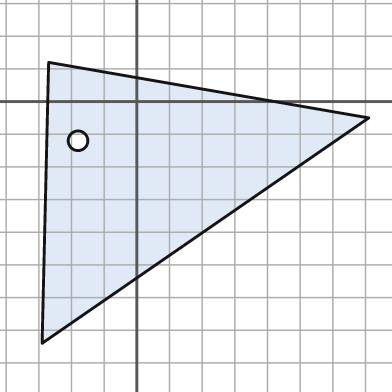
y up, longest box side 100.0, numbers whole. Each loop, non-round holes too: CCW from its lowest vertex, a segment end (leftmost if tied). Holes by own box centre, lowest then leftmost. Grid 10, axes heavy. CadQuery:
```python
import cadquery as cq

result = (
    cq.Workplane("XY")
    .moveTo(-29.0, -74.0)
    .lineTo(71.0, -5.0)
    .lineTo(-27.0, 12.0)
    .close()
    .moveTo(-18.0, -12.0)
    .circle(3.0)
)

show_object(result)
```